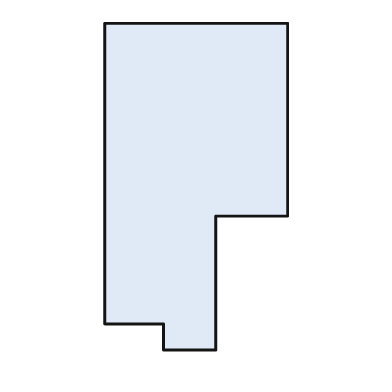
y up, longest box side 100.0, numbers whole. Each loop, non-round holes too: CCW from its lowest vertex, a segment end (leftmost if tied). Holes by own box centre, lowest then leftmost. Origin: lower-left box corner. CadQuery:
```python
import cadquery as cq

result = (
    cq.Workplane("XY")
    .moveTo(18.0, 0.0)
    .lineTo(34.0, 0.0)
    .lineTo(34.0, 41.0)
    .lineTo(56.0, 41.0)
    .lineTo(56.0, 100.0)
    .lineTo(0.0, 100.0)
    .lineTo(0.0, 8.0)
    .lineTo(18.0, 8.0)
    .close()
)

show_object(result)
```